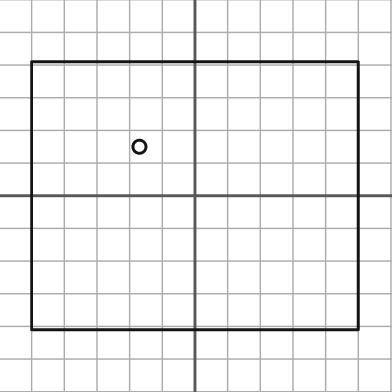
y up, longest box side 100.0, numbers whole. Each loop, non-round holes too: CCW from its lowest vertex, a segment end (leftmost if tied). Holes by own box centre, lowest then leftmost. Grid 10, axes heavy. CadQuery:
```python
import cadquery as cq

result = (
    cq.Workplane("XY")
    .moveTo(-50.0, -41.0)
    .lineTo(50.0, -41.0)
    .lineTo(50.0, 41.0)
    .lineTo(-50.0, 41.0)
    .close()
    .moveTo(-17.0, 15.0)
    .circle(2.0)
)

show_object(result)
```